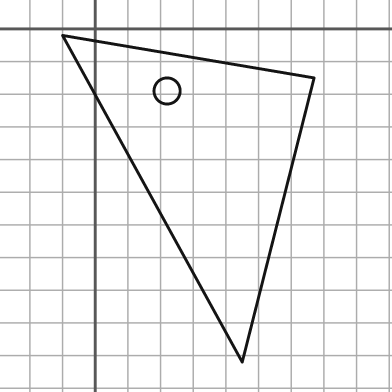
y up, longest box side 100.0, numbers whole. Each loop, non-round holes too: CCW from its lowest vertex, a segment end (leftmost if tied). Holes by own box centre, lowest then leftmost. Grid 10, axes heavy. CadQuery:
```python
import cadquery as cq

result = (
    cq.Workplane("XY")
    .moveTo(45.0, -102.0)
    .lineTo(67.0, -15.0)
    .lineTo(-10.0, -2.0)
    .close()
    .moveTo(22.0, -19.0)
    .circle(4.0)
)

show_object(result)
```